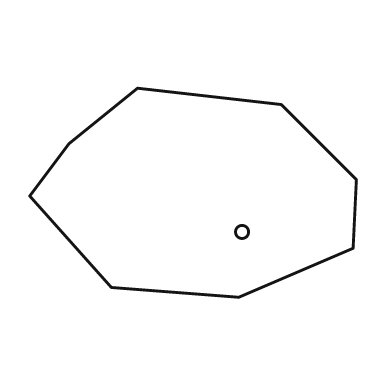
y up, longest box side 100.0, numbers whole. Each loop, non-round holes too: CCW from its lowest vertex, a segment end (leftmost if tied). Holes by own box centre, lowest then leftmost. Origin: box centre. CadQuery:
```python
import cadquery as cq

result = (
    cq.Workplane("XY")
    .moveTo(14.0, -32.0)
    .lineTo(49.0, -17.0)
    .lineTo(50.0, 4.0)
    .lineTo(27.0, 27.0)
    .lineTo(-17.0, 32.0)
    .lineTo(-38.0, 15.0)
    .lineTo(-50.0, -1.0)
    .lineTo(-25.0, -29.0)
    .close()
    .moveTo(15.0, -12.0)
    .circle(2.0)
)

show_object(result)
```